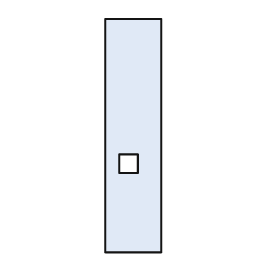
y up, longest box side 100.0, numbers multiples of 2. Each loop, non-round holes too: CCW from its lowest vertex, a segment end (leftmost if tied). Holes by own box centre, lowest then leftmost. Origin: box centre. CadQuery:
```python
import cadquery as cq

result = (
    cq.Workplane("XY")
    .moveTo(-12.0, -50.0)
    .lineTo(12.0, -50.0)
    .lineTo(12.0, 50.0)
    .lineTo(-12.0, 50.0)
    .close()
    .moveTo(-6.0, -16.0)
    .lineTo(2.0, -16.0)
    .lineTo(2.0, -8.0)
    .lineTo(-6.0, -8.0)
    .close()
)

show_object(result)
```